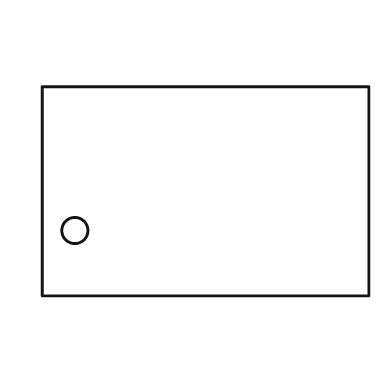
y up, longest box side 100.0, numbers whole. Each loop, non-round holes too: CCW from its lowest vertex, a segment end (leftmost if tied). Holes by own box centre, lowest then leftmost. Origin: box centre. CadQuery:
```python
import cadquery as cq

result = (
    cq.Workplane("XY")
    .moveTo(-50.0, -32.0)
    .lineTo(50.0, -32.0)
    .lineTo(50.0, 32.0)
    .lineTo(-50.0, 32.0)
    .close()
    .moveTo(-40.0, -12.0)
    .circle(4.0)
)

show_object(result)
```